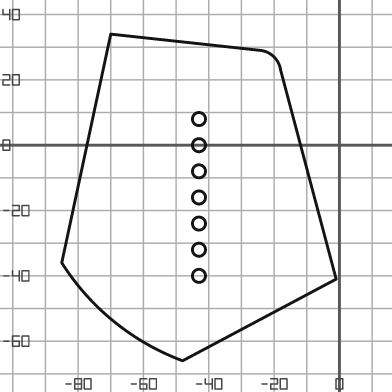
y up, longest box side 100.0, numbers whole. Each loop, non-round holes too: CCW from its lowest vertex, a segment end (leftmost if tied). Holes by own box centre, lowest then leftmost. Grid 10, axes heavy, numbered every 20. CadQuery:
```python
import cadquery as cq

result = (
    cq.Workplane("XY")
    .moveTo(-48.0, -66.0)
    .lineTo(-1.0, -41.0)
    .lineTo(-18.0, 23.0)
    .threePointArc((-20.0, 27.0), (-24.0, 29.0))
    .lineTo(-70.0, 34.0)
    .lineTo(-85.0, -36.0)
    .threePointArc((-69.0, -54.0), (-48.0, -66.0))
    .close()
    .moveTo(-43.0, -40.0)
    .circle(2.0)
    .moveTo(-43.0, -32.0)
    .circle(2.0)
    .moveTo(-43.0, -24.0)
    .circle(2.0)
    .moveTo(-43.0, -16.0)
    .circle(2.0)
    .moveTo(-43.0, -8.0)
    .circle(2.0)
    .moveTo(-43.0, 0.0)
    .circle(2.0)
    .moveTo(-43.0, 8.0)
    .circle(2.0)
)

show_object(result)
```